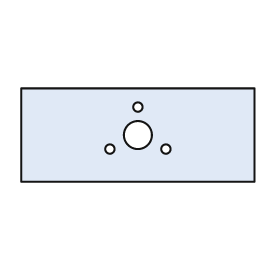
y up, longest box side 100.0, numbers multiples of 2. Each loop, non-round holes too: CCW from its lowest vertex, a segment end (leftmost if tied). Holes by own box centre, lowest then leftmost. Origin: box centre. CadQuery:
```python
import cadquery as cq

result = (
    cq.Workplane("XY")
    .moveTo(-50.0, -20.0)
    .lineTo(50.0, -20.0)
    .lineTo(50.0, 20.0)
    .lineTo(-50.0, 20.0)
    .close()
    .moveTo(-12.0, -6.0)
    .circle(2.0)
    .moveTo(12.0, -6.0)
    .circle(2.0)
    .moveTo(0.0, 0.0)
    .circle(6.0)
    .moveTo(0.0, 12.0)
    .circle(2.0)
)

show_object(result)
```